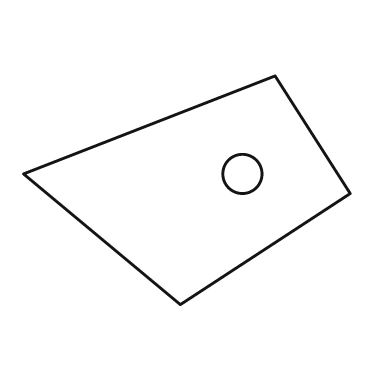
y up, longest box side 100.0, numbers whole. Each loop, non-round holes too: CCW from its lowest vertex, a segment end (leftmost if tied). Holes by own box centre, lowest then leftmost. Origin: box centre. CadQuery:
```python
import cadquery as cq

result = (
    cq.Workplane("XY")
    .moveTo(-2.0, -35.0)
    .lineTo(50.0, -1.0)
    .lineTo(27.0, 35.0)
    .lineTo(-50.0, 5.0)
    .close()
    .moveTo(17.0, 5.0)
    .circle(6.0)
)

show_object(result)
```